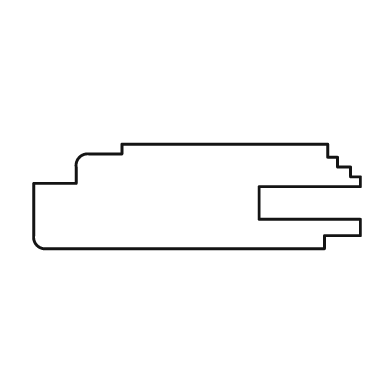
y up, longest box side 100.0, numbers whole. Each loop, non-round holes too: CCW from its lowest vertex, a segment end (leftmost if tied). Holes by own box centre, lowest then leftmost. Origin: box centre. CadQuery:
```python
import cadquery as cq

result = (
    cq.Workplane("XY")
    .moveTo(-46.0, -16.0)
    .lineTo(39.0, -16.0)
    .lineTo(39.0, -12.0)
    .lineTo(50.0, -12.0)
    .lineTo(50.0, -7.0)
    .lineTo(19.0, -7.0)
    .lineTo(19.0, 3.0)
    .lineTo(50.0, 3.0)
    .lineTo(50.0, 6.0)
    .lineTo(47.0, 6.0)
    .lineTo(47.0, 9.0)
    .lineTo(43.0, 9.0)
    .lineTo(43.0, 12.0)
    .lineTo(40.0, 12.0)
    .lineTo(40.0, 16.0)
    .lineTo(-23.0, 16.0)
    .lineTo(-23.0, 13.0)
    .lineTo(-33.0, 13.0)
    .threePointArc((-36.0, 12.0), (-37.0, 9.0))
    .lineTo(-37.0, 4.0)
    .lineTo(-50.0, 4.0)
    .lineTo(-50.0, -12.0)
    .threePointArc((-49.0, -15.0), (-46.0, -16.0))
    .close()
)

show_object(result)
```